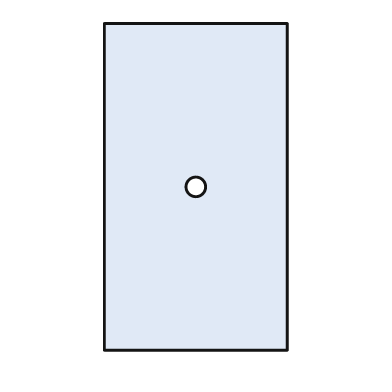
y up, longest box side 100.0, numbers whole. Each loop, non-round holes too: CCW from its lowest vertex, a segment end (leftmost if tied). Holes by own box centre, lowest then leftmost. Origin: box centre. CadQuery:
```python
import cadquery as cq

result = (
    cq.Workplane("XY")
    .moveTo(-28.0, -50.0)
    .lineTo(28.0, -50.0)
    .lineTo(28.0, 50.0)
    .lineTo(-28.0, 50.0)
    .close()
    .moveTo(0.0, 0.0)
    .circle(3.0)
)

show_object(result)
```